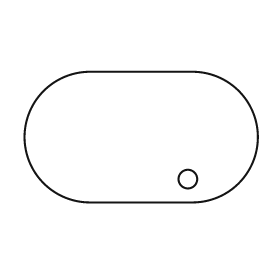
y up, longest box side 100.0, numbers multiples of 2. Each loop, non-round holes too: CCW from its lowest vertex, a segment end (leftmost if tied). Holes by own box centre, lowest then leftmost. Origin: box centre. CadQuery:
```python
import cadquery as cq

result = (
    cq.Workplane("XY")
    .moveTo(-22.0, -28.0)
    .lineTo(22.0, -28.0)
    .threePointArc((50.0, 0.0), (22.0, 28.0))
    .lineTo(-22.0, 28.0)
    .threePointArc((-50.0, 0.0), (-22.0, -28.0))
    .close()
    .moveTo(20.0, -18.0)
    .circle(4.0)
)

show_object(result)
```